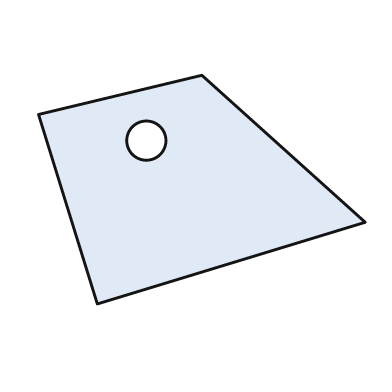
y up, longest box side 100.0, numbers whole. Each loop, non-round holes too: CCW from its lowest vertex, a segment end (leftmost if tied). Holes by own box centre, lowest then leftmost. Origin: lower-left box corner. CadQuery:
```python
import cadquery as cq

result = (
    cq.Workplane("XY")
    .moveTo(18.0, 0.0)
    .lineTo(100.0, 25.0)
    .lineTo(50.0, 70.0)
    .lineTo(0.0, 58.0)
    .close()
    .moveTo(33.0, 50.0)
    .circle(6.0)
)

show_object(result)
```